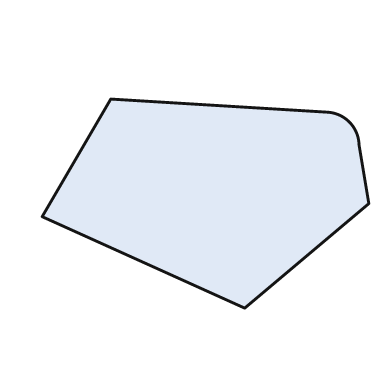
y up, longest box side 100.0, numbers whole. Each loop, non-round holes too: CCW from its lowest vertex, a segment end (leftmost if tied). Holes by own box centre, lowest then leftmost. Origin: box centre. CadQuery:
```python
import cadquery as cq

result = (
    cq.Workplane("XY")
    .moveTo(12.0, -32.0)
    .lineTo(50.0, 0.0)
    .lineTo(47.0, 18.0)
    .threePointArc((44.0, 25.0), (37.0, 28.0))
    .lineTo(-29.0, 32.0)
    .lineTo(-50.0, -4.0)
    .close()
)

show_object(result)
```